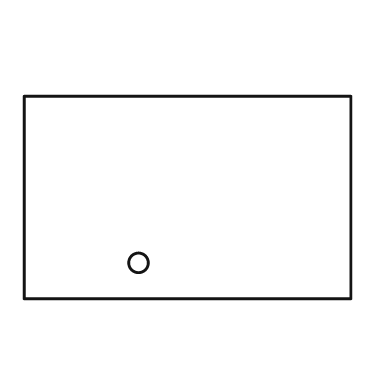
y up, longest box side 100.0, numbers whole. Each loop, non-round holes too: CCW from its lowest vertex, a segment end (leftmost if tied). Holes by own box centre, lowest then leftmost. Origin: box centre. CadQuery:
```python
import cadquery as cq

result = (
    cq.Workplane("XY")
    .moveTo(-50.0, -31.0)
    .lineTo(50.0, -31.0)
    .lineTo(50.0, 31.0)
    .lineTo(-50.0, 31.0)
    .close()
    .moveTo(-15.0, -20.0)
    .circle(3.0)
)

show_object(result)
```